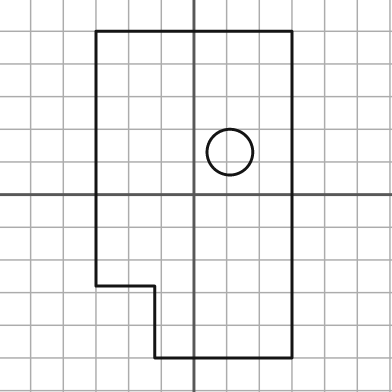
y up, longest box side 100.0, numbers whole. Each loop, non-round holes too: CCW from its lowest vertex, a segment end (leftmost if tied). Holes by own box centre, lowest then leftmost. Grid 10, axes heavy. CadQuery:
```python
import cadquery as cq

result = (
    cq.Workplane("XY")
    .moveTo(-12.0, -50.0)
    .lineTo(30.0, -50.0)
    .lineTo(30.0, 50.0)
    .lineTo(-30.0, 50.0)
    .lineTo(-30.0, -28.0)
    .lineTo(-12.0, -28.0)
    .close()
    .moveTo(11.0, 13.0)
    .circle(7.0)
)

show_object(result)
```